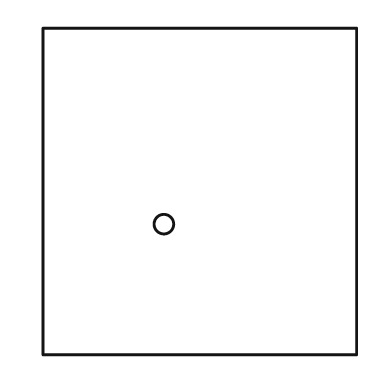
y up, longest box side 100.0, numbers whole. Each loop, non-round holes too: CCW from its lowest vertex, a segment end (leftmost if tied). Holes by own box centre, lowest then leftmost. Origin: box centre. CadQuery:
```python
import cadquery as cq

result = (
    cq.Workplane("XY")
    .moveTo(-48.0, -50.0)
    .lineTo(48.0, -50.0)
    .lineTo(48.0, 50.0)
    .lineTo(-48.0, 50.0)
    .close()
    .moveTo(-11.0, -10.0)
    .circle(3.0)
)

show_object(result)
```